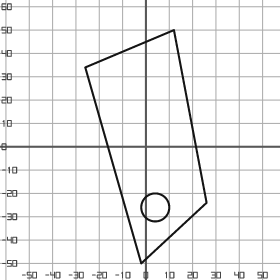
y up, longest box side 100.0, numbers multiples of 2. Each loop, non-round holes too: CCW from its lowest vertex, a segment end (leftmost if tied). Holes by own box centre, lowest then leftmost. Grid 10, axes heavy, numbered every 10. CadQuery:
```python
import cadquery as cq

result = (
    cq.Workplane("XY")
    .moveTo(-2.0, -50.0)
    .lineTo(26.0, -24.0)
    .lineTo(12.0, 50.0)
    .lineTo(-26.0, 34.0)
    .close()
    .moveTo(4.0, -26.0)
    .circle(6.0)
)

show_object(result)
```